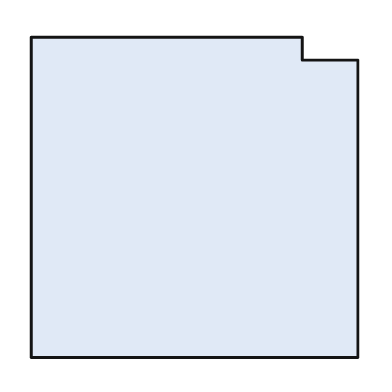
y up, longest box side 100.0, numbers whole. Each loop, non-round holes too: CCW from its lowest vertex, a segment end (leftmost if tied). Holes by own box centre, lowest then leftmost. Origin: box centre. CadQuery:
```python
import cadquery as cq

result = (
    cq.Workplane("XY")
    .moveTo(-50.0, -49.0)
    .lineTo(50.0, -49.0)
    .lineTo(50.0, 42.0)
    .lineTo(33.0, 42.0)
    .lineTo(33.0, 49.0)
    .lineTo(-50.0, 49.0)
    .close()
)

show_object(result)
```